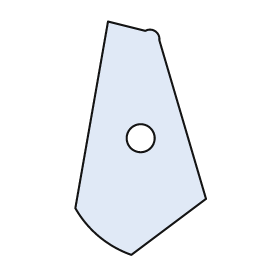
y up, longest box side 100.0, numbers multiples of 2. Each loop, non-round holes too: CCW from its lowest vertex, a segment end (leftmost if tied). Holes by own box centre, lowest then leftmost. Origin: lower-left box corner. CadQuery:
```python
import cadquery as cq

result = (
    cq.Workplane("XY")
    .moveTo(24.0, 0.0)
    .lineTo(56.0, 24.0)
    .lineTo(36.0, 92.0)
    .threePointArc((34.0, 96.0), (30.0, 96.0))
    .lineTo(14.0, 100.0)
    .lineTo(0.0, 20.0)
    .threePointArc((10.0, 8.0), (24.0, 0.0))
    .close()
    .moveTo(28.0, 50.0)
    .circle(6.0)
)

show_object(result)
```